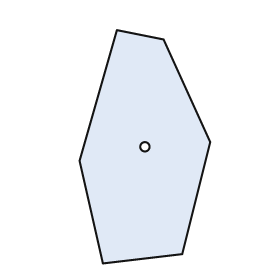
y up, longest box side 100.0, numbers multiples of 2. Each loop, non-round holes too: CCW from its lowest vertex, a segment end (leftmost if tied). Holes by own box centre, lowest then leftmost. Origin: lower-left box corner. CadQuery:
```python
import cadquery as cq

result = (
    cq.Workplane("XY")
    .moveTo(10.0, 0.0)
    .lineTo(44.0, 4.0)
    .lineTo(56.0, 52.0)
    .lineTo(36.0, 96.0)
    .lineTo(16.0, 100.0)
    .lineTo(0.0, 44.0)
    .close()
    .moveTo(28.0, 50.0)
    .circle(2.0)
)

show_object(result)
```